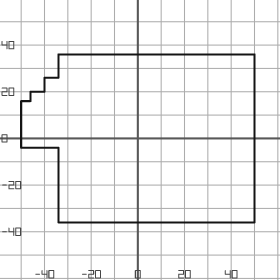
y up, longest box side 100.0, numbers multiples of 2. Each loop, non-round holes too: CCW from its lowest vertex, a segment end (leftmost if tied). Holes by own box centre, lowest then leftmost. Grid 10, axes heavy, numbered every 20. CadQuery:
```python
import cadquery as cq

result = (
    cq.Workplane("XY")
    .moveTo(-34.0, -36.0)
    .lineTo(50.0, -36.0)
    .lineTo(50.0, 36.0)
    .lineTo(-34.0, 36.0)
    .lineTo(-34.0, 26.0)
    .lineTo(-40.0, 26.0)
    .lineTo(-40.0, 20.0)
    .lineTo(-46.0, 20.0)
    .lineTo(-46.0, 16.0)
    .lineTo(-50.0, 16.0)
    .lineTo(-50.0, -4.0)
    .lineTo(-34.0, -4.0)
    .close()
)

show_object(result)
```